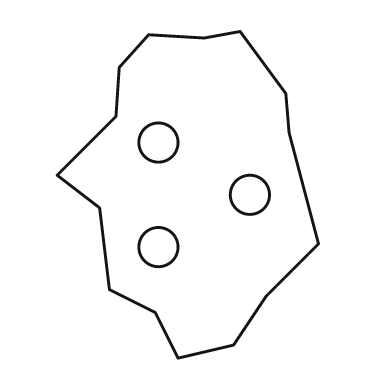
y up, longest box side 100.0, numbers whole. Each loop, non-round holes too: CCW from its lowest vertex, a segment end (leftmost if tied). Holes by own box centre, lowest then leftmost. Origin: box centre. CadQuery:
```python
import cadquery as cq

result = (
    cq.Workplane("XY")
    .moveTo(-3.0, -50.0)
    .lineTo(14.0, -46.0)
    .lineTo(24.0, -31.0)
    .lineTo(40.0, -15.0)
    .lineTo(31.0, 19.0)
    .lineTo(30.0, 31.0)
    .lineTo(16.0, 50.0)
    .lineTo(5.0, 48.0)
    .lineTo(-12.0, 49.0)
    .lineTo(-21.0, 39.0)
    .lineTo(-22.0, 24.0)
    .lineTo(-40.0, 6.0)
    .lineTo(-27.0, -4.0)
    .lineTo(-24.0, -29.0)
    .lineTo(-10.0, -36.0)
    .close()
    .moveTo(-9.0, -16.0)
    .circle(6.0)
    .moveTo(19.0, 0.0)
    .circle(6.0)
    .moveTo(-9.0, 16.0)
    .circle(6.0)
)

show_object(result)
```